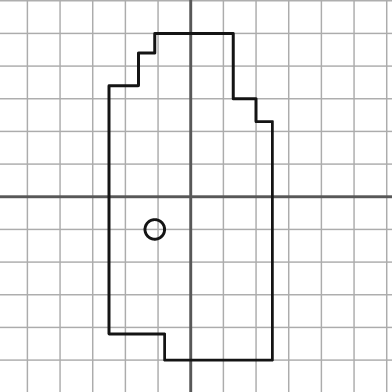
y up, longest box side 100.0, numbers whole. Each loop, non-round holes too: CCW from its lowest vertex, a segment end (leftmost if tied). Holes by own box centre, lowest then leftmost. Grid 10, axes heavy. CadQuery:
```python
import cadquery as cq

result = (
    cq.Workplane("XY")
    .moveTo(-8.0, -50.0)
    .lineTo(25.0, -50.0)
    .lineTo(25.0, 23.0)
    .lineTo(20.0, 23.0)
    .lineTo(20.0, 30.0)
    .lineTo(13.0, 30.0)
    .lineTo(13.0, 50.0)
    .lineTo(-11.0, 50.0)
    .lineTo(-11.0, 44.0)
    .lineTo(-16.0, 44.0)
    .lineTo(-16.0, 34.0)
    .lineTo(-25.0, 34.0)
    .lineTo(-25.0, -42.0)
    .lineTo(-8.0, -42.0)
    .close()
    .moveTo(-11.0, -10.0)
    .circle(3.0)
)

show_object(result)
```